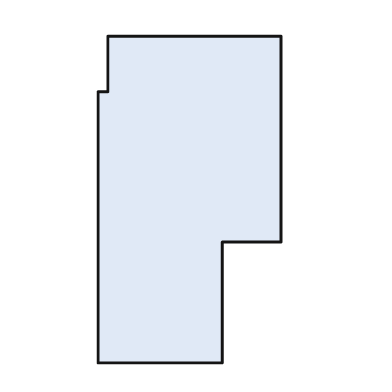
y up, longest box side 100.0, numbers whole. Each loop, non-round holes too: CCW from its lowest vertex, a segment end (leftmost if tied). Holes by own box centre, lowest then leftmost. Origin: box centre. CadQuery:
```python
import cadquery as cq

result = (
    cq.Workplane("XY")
    .moveTo(-28.0, -50.0)
    .lineTo(10.0, -50.0)
    .lineTo(10.0, -13.0)
    .lineTo(28.0, -13.0)
    .lineTo(28.0, 50.0)
    .lineTo(-25.0, 50.0)
    .lineTo(-25.0, 33.0)
    .lineTo(-28.0, 33.0)
    .close()
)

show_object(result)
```